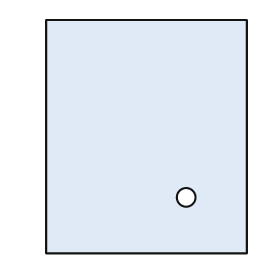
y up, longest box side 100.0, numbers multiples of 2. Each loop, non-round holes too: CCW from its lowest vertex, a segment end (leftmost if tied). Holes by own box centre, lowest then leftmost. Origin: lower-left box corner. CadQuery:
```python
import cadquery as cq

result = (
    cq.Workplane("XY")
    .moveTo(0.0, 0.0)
    .lineTo(86.0, 0.0)
    .lineTo(86.0, 100.0)
    .lineTo(0.0, 100.0)
    .close()
    .moveTo(60.0, 24.0)
    .circle(4.0)
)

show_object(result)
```